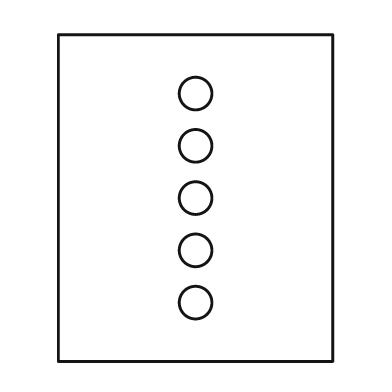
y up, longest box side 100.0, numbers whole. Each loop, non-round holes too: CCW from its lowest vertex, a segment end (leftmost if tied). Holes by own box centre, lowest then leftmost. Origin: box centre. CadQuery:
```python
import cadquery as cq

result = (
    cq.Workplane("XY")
    .moveTo(-42.0, -50.0)
    .lineTo(42.0, -50.0)
    .lineTo(42.0, 50.0)
    .lineTo(-42.0, 50.0)
    .close()
    .moveTo(0.0, -32.0)
    .circle(5.0)
    .moveTo(0.0, -16.0)
    .circle(5.0)
    .moveTo(0.0, 0.0)
    .circle(5.0)
    .moveTo(0.0, 16.0)
    .circle(5.0)
    .moveTo(0.0, 32.0)
    .circle(5.0)
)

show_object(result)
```